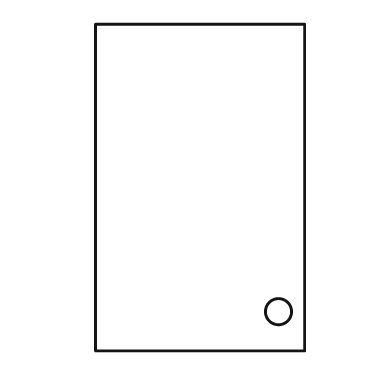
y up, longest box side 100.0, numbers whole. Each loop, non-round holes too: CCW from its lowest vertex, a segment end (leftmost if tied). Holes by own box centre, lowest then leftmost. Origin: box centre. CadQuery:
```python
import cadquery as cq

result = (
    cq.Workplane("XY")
    .moveTo(-32.0, -50.0)
    .lineTo(32.0, -50.0)
    .lineTo(32.0, 50.0)
    .lineTo(-32.0, 50.0)
    .close()
    .moveTo(24.0, -38.0)
    .circle(4.0)
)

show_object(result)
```